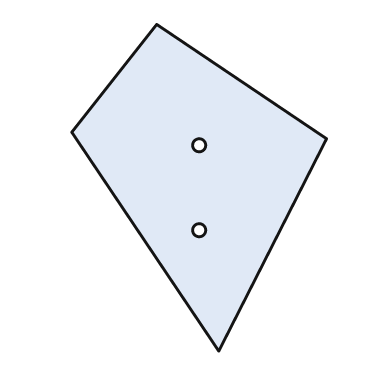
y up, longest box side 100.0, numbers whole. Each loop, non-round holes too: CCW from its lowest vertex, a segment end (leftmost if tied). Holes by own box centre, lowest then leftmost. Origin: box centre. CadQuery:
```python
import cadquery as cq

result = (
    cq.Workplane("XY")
    .moveTo(6.0, -50.0)
    .lineTo(39.0, 15.0)
    .lineTo(-13.0, 50.0)
    .lineTo(-39.0, 17.0)
    .close()
    .moveTo(0.0, -13.0)
    .circle(2.0)
    .moveTo(0.0, 13.0)
    .circle(2.0)
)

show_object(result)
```